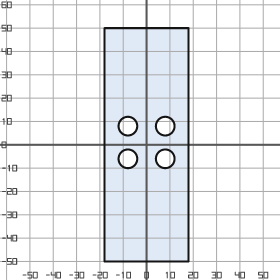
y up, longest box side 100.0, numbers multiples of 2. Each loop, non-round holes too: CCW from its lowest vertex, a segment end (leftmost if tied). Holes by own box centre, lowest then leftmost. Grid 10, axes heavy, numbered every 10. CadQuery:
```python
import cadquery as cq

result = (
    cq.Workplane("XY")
    .moveTo(-18.0, -50.0)
    .lineTo(18.0, -50.0)
    .lineTo(18.0, 50.0)
    .lineTo(-18.0, 50.0)
    .close()
    .moveTo(-8.0, -6.0)
    .circle(4.0)
    .moveTo(8.0, -6.0)
    .circle(4.0)
    .moveTo(-8.0, 8.0)
    .circle(4.0)
    .moveTo(8.0, 8.0)
    .circle(4.0)
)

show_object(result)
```